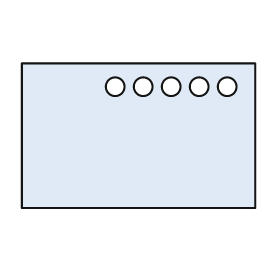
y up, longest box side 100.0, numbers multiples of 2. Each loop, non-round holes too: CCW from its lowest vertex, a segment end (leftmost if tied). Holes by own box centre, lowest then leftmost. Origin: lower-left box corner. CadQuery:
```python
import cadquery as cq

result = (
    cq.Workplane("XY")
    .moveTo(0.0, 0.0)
    .lineTo(100.0, 0.0)
    .lineTo(100.0, 62.0)
    .lineTo(0.0, 62.0)
    .close()
    .moveTo(40.0, 52.0)
    .circle(4.0)
    .moveTo(52.0, 52.0)
    .circle(4.0)
    .moveTo(64.0, 52.0)
    .circle(4.0)
    .moveTo(76.0, 52.0)
    .circle(4.0)
    .moveTo(88.0, 52.0)
    .circle(4.0)
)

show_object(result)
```